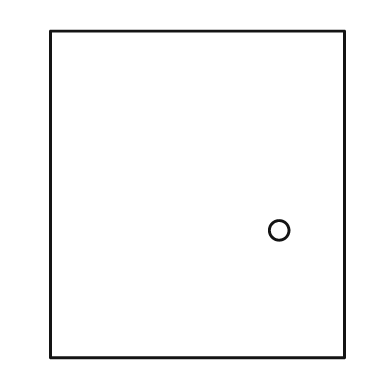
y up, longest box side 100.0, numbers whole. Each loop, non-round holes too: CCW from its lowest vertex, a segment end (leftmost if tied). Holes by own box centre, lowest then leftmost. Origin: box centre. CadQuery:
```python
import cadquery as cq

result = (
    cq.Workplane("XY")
    .moveTo(-45.0, -50.0)
    .lineTo(45.0, -50.0)
    .lineTo(45.0, 50.0)
    .lineTo(-45.0, 50.0)
    .close()
    .moveTo(25.0, -11.0)
    .circle(3.0)
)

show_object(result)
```